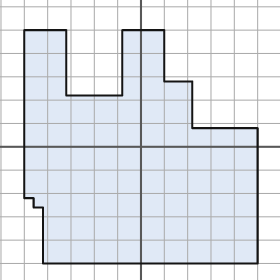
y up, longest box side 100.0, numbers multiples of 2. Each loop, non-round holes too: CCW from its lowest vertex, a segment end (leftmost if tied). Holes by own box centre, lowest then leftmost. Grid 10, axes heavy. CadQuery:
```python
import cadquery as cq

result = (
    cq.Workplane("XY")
    .moveTo(-42.0, -50.0)
    .lineTo(50.0, -50.0)
    .lineTo(50.0, 8.0)
    .lineTo(22.0, 8.0)
    .lineTo(22.0, 28.0)
    .lineTo(10.0, 28.0)
    .lineTo(10.0, 50.0)
    .lineTo(-8.0, 50.0)
    .lineTo(-8.0, 22.0)
    .lineTo(-32.0, 22.0)
    .lineTo(-32.0, 50.0)
    .lineTo(-50.0, 50.0)
    .lineTo(-50.0, -22.0)
    .lineTo(-46.0, -22.0)
    .lineTo(-46.0, -26.0)
    .lineTo(-42.0, -26.0)
    .close()
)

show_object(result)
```